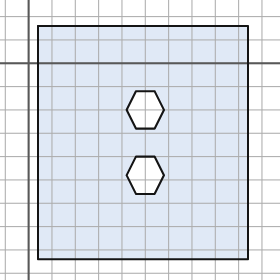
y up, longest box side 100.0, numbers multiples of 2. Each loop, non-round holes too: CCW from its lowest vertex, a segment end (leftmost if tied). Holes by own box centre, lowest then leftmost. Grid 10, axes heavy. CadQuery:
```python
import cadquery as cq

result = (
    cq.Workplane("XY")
    .moveTo(4.0, -84.0)
    .lineTo(94.0, -84.0)
    .lineTo(94.0, 16.0)
    .lineTo(4.0, 16.0)
    .close()
    .moveTo(46.0, -56.0)
    .lineTo(54.0, -56.0)
    .lineTo(58.0, -48.0)
    .lineTo(54.0, -40.0)
    .lineTo(46.0, -40.0)
    .lineTo(42.0, -48.0)
    .close()
    .moveTo(46.0, -28.0)
    .lineTo(54.0, -28.0)
    .lineTo(58.0, -20.0)
    .lineTo(54.0, -12.0)
    .lineTo(46.0, -12.0)
    .lineTo(42.0, -20.0)
    .close()
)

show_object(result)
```